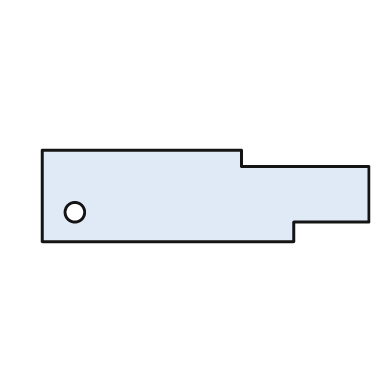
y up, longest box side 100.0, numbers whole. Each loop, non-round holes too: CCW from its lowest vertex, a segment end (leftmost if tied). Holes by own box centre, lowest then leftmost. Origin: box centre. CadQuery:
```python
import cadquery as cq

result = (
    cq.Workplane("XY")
    .moveTo(-50.0, -14.0)
    .lineTo(27.0, -14.0)
    .lineTo(27.0, -8.0)
    .lineTo(50.0, -8.0)
    .lineTo(50.0, 9.0)
    .lineTo(11.0, 9.0)
    .lineTo(11.0, 14.0)
    .lineTo(-50.0, 14.0)
    .close()
    .moveTo(-40.0, -5.0)
    .circle(3.0)
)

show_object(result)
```